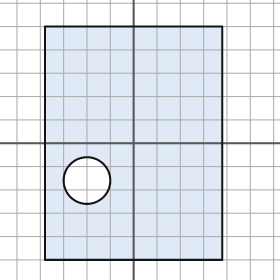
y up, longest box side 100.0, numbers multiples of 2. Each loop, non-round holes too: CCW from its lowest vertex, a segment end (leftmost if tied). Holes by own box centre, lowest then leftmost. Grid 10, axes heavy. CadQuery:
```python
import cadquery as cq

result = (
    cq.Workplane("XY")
    .moveTo(-38.0, -50.0)
    .lineTo(38.0, -50.0)
    .lineTo(38.0, 50.0)
    .lineTo(-38.0, 50.0)
    .close()
    .moveTo(-20.0, -16.0)
    .circle(10.0)
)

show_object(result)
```